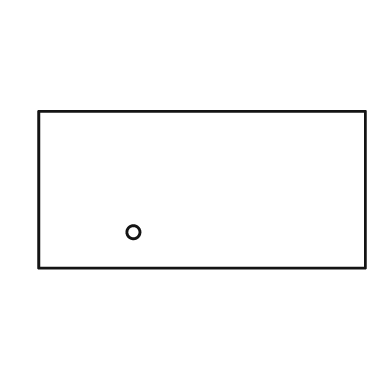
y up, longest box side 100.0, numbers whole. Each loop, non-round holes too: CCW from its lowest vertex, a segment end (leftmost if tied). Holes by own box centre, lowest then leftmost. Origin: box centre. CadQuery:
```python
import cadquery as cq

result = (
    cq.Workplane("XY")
    .moveTo(-50.0, -24.0)
    .lineTo(50.0, -24.0)
    .lineTo(50.0, 24.0)
    .lineTo(-50.0, 24.0)
    .close()
    .moveTo(-21.0, -13.0)
    .circle(2.0)
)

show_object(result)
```